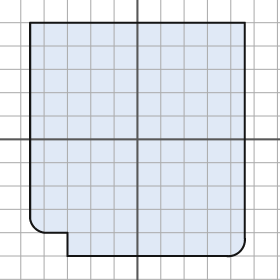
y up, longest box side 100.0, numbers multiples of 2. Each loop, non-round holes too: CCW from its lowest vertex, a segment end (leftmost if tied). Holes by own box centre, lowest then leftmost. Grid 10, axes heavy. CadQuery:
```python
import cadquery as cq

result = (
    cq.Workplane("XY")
    .moveTo(-30.0, -50.0)
    .lineTo(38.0, -50.0)
    .threePointArc((44.0, -48.0), (46.0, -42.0))
    .lineTo(46.0, 50.0)
    .lineTo(-46.0, 50.0)
    .lineTo(-46.0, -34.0)
    .threePointArc((-44.0, -38.0), (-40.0, -40.0))
    .lineTo(-30.0, -40.0)
    .close()
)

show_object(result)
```